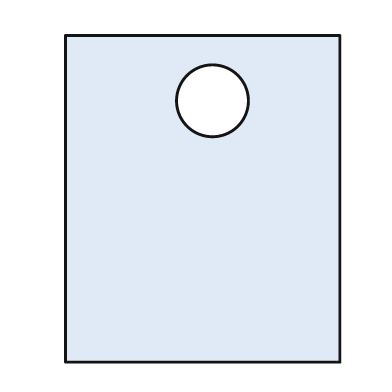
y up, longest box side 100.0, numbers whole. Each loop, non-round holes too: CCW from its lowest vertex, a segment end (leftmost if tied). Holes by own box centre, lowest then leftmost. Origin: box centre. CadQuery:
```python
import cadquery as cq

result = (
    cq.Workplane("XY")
    .moveTo(-42.0, -50.0)
    .lineTo(42.0, -50.0)
    .lineTo(42.0, 50.0)
    .lineTo(-42.0, 50.0)
    .close()
    .moveTo(3.0, 30.0)
    .circle(11.0)
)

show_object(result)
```